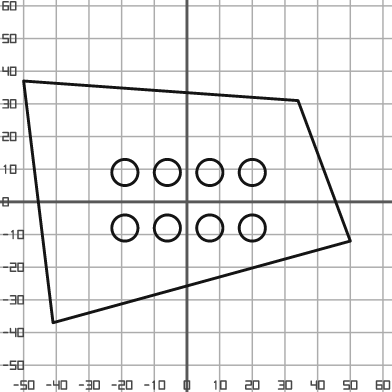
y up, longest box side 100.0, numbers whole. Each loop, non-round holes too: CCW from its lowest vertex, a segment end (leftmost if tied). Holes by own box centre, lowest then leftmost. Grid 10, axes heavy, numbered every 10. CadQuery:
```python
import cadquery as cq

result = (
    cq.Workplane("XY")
    .moveTo(-41.0, -37.0)
    .lineTo(50.0, -12.0)
    .lineTo(34.0, 31.0)
    .lineTo(-50.0, 37.0)
    .close()
    .moveTo(-19.0, -8.0)
    .circle(4.0)
    .moveTo(-6.0, -8.0)
    .circle(4.0)
    .moveTo(7.0, -8.0)
    .circle(4.0)
    .moveTo(20.0, -8.0)
    .circle(4.0)
    .moveTo(-19.0, 9.0)
    .circle(4.0)
    .moveTo(-6.0, 9.0)
    .circle(4.0)
    .moveTo(7.0, 9.0)
    .circle(4.0)
    .moveTo(20.0, 9.0)
    .circle(4.0)
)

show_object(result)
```